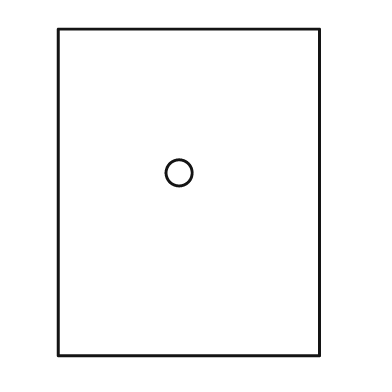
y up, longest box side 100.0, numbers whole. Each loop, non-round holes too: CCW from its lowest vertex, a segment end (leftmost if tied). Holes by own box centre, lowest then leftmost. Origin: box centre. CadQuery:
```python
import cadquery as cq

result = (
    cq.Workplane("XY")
    .moveTo(-40.0, -50.0)
    .lineTo(40.0, -50.0)
    .lineTo(40.0, 50.0)
    .lineTo(-40.0, 50.0)
    .close()
    .moveTo(-3.0, 6.0)
    .circle(4.0)
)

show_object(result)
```